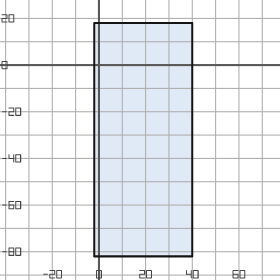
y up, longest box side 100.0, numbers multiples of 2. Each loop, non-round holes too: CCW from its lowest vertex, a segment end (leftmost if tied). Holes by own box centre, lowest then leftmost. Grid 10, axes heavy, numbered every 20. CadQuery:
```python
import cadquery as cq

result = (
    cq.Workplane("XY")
    .moveTo(-2.0, -82.0)
    .lineTo(40.0, -82.0)
    .lineTo(40.0, 18.0)
    .lineTo(-2.0, 18.0)
    .close()
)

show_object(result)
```